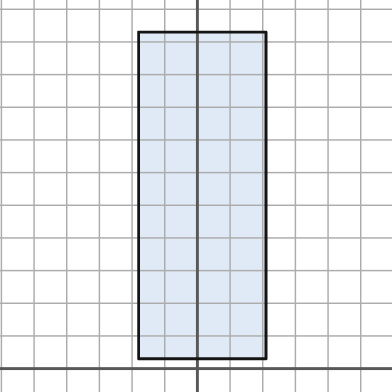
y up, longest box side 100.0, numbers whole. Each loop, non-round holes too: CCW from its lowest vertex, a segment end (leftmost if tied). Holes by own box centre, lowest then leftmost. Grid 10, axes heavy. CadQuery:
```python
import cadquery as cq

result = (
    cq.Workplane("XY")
    .moveTo(-18.0, 3.0)
    .lineTo(21.0, 3.0)
    .lineTo(21.0, 103.0)
    .lineTo(-18.0, 103.0)
    .close()
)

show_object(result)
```